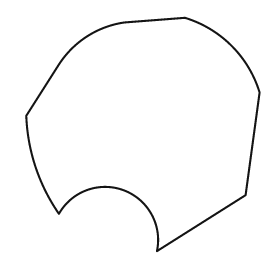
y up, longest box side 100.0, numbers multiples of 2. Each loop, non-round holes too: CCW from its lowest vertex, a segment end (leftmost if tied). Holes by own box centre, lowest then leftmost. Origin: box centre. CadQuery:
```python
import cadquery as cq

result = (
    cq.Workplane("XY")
    .moveTo(6.0, -50.0)
    .lineTo(44.0, -26.0)
    .lineTo(50.0, 18.0)
    .threePointArc((38.0, 38.0), (18.0, 50.0))
    .lineTo(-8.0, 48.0)
    .threePointArc((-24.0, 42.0), (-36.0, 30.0))
    .lineTo(-50.0, 8.0)
    .threePointArc((-46.0, -14.0), (-36.0, -34.0))
    .threePointArc((-8.0, -24.0), (6.0, -50.0))
    .close()
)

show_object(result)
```